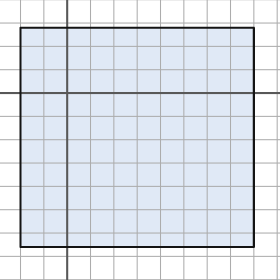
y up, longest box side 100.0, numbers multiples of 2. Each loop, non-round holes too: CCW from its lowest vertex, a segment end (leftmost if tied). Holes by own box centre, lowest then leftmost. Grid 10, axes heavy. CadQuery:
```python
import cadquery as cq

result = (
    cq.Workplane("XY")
    .moveTo(-20.0, -66.0)
    .lineTo(80.0, -66.0)
    .lineTo(80.0, 28.0)
    .lineTo(-20.0, 28.0)
    .close()
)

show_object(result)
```